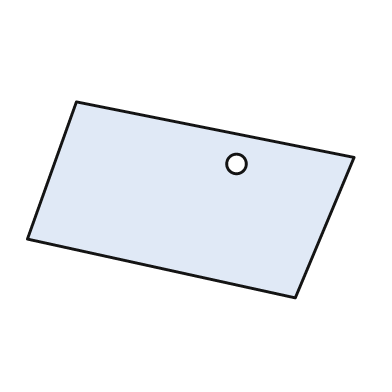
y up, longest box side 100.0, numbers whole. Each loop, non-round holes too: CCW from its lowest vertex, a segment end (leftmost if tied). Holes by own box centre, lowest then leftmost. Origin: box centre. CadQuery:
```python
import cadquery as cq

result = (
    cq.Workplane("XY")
    .moveTo(32.0, -30.0)
    .lineTo(50.0, 13.0)
    .lineTo(-35.0, 30.0)
    .lineTo(-50.0, -12.0)
    .close()
    .moveTo(14.0, 11.0)
    .circle(3.0)
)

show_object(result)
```